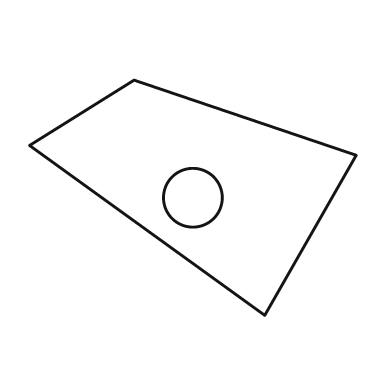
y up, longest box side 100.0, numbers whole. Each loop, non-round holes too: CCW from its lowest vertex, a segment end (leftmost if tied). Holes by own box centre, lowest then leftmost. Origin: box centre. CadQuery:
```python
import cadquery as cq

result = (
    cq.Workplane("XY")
    .moveTo(22.0, -36.0)
    .lineTo(50.0, 13.0)
    .lineTo(-18.0, 36.0)
    .lineTo(-50.0, 16.0)
    .close()
    .moveTo(0.0, 0.0)
    .circle(9.0)
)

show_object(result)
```